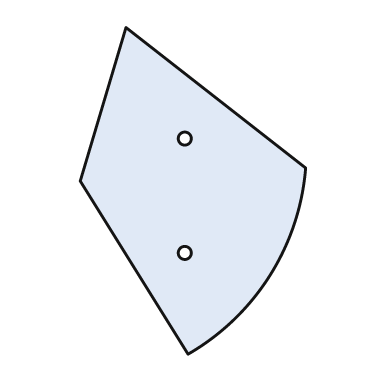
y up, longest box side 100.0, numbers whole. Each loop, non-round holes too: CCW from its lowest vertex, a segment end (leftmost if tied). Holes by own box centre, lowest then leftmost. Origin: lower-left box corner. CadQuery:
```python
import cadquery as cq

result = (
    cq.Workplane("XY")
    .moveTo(33.0, 0.0)
    .threePointArc((58.0, 24.0), (69.0, 57.0))
    .lineTo(14.0, 100.0)
    .lineTo(0.0, 53.0)
    .close()
    .moveTo(32.0, 31.0)
    .circle(2.0)
    .moveTo(32.0, 66.0)
    .circle(2.0)
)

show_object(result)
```